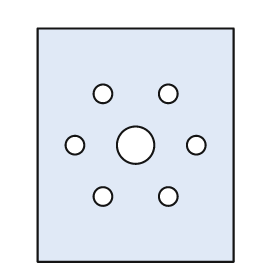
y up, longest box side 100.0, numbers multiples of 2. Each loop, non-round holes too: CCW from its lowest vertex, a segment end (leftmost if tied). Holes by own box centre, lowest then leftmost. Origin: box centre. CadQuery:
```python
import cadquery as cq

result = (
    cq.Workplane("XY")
    .moveTo(-42.0, -50.0)
    .lineTo(42.0, -50.0)
    .lineTo(42.0, 50.0)
    .lineTo(-42.0, 50.0)
    .close()
    .moveTo(-14.0, -22.0)
    .circle(4.0)
    .moveTo(14.0, -22.0)
    .circle(4.0)
    .moveTo(-26.0, 0.0)
    .circle(4.0)
    .moveTo(0.0, 0.0)
    .circle(8.0)
    .moveTo(26.0, 0.0)
    .circle(4.0)
    .moveTo(-14.0, 22.0)
    .circle(4.0)
    .moveTo(14.0, 22.0)
    .circle(4.0)
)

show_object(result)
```